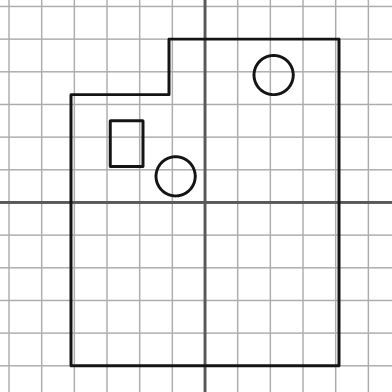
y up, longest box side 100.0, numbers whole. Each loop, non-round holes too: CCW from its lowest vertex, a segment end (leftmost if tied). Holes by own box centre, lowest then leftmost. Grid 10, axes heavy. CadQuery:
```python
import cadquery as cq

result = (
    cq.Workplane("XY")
    .moveTo(-41.0, -50.0)
    .lineTo(41.0, -50.0)
    .lineTo(41.0, 50.0)
    .lineTo(-11.0, 50.0)
    .lineTo(-11.0, 33.0)
    .lineTo(-41.0, 33.0)
    .close()
    .moveTo(-9.0, 8.0)
    .circle(6.0)
    .moveTo(-29.0, 11.0)
    .lineTo(-19.0, 11.0)
    .lineTo(-19.0, 25.0)
    .lineTo(-29.0, 25.0)
    .close()
    .moveTo(21.0, 39.0)
    .circle(6.0)
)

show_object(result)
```